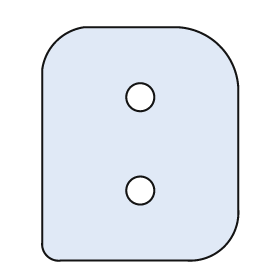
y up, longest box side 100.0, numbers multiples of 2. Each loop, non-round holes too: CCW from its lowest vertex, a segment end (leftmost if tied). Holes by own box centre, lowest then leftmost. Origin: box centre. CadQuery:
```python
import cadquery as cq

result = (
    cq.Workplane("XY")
    .moveTo(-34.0, -50.0)
    .lineTo(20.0, -50.0)
    .threePointArc((36.0, -44.0), (42.0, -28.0))
    .lineTo(42.0, 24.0)
    .threePointArc((34.0, 42.0), (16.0, 50.0))
    .lineTo(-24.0, 50.0)
    .threePointArc((-36.0, 44.0), (-42.0, 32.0))
    .lineTo(-42.0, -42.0)
    .threePointArc((-40.0, -48.0), (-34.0, -50.0))
    .close()
    .moveTo(0.0, -20.0)
    .circle(6.0)
    .moveTo(0.0, 20.0)
    .circle(6.0)
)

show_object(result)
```